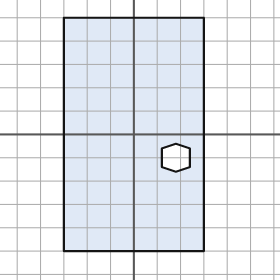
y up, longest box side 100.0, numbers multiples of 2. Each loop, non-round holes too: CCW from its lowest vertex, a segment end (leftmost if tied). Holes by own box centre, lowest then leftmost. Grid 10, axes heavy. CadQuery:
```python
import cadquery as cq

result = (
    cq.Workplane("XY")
    .moveTo(-30.0, -50.0)
    .lineTo(30.0, -50.0)
    .lineTo(30.0, 50.0)
    .lineTo(-30.0, 50.0)
    .close()
    .moveTo(18.0, -16.0)
    .lineTo(24.0, -14.0)
    .lineTo(24.0, -6.0)
    .lineTo(18.0, -4.0)
    .lineTo(12.0, -6.0)
    .lineTo(12.0, -14.0)
    .close()
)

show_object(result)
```